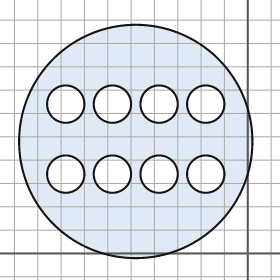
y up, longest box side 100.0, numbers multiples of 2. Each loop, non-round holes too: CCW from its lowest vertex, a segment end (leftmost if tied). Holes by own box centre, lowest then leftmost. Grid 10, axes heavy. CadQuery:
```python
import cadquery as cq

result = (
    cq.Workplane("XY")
    .moveTo(-48.0, 48.0)
    .circle(50.0)
    .moveTo(-78.0, 34.0)
    .circle(8.0)
    .moveTo(-58.0, 34.0)
    .circle(8.0)
    .moveTo(-38.0, 34.0)
    .circle(8.0)
    .moveTo(-18.0, 34.0)
    .circle(8.0)
    .moveTo(-78.0, 64.0)
    .circle(8.0)
    .moveTo(-58.0, 64.0)
    .circle(8.0)
    .moveTo(-38.0, 64.0)
    .circle(8.0)
    .moveTo(-18.0, 64.0)
    .circle(8.0)
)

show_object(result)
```